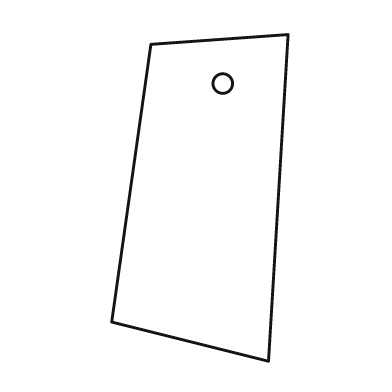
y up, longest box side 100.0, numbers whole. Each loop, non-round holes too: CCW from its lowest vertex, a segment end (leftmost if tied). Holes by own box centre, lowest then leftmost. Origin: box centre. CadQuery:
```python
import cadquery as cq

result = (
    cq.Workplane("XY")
    .moveTo(21.0, -50.0)
    .lineTo(27.0, 50.0)
    .lineTo(-15.0, 47.0)
    .lineTo(-27.0, -38.0)
    .close()
    .moveTo(7.0, 35.0)
    .circle(3.0)
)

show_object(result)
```